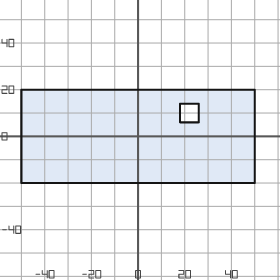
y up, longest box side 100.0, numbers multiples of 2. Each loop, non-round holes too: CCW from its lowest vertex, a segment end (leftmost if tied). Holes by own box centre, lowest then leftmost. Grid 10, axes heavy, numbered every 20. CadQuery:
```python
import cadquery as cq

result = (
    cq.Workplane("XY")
    .moveTo(-50.0, -20.0)
    .lineTo(50.0, -20.0)
    .lineTo(50.0, 20.0)
    .lineTo(-50.0, 20.0)
    .close()
    .moveTo(18.0, 6.0)
    .lineTo(26.0, 6.0)
    .lineTo(26.0, 14.0)
    .lineTo(18.0, 14.0)
    .close()
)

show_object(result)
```